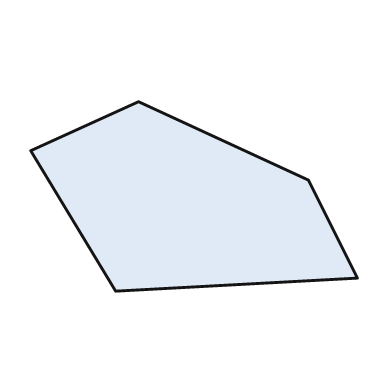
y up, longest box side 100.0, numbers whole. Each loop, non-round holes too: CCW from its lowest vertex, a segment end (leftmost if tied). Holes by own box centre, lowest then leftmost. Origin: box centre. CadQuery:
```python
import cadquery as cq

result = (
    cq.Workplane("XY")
    .moveTo(-24.0, -29.0)
    .lineTo(50.0, -25.0)
    .lineTo(35.0, 5.0)
    .lineTo(-17.0, 29.0)
    .lineTo(-50.0, 14.0)
    .close()
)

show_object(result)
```